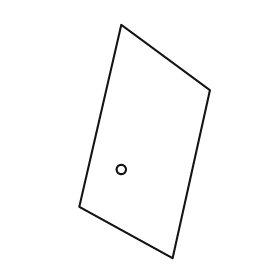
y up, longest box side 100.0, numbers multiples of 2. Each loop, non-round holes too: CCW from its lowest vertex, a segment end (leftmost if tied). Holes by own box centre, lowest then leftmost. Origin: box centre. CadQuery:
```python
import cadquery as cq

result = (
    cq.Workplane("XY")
    .moveTo(12.0, -50.0)
    .lineTo(28.0, 22.0)
    .lineTo(-10.0, 50.0)
    .lineTo(-28.0, -28.0)
    .close()
    .moveTo(-10.0, -12.0)
    .circle(2.0)
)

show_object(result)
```